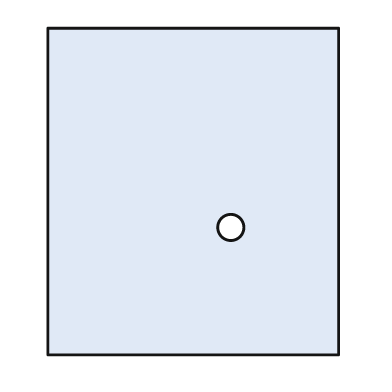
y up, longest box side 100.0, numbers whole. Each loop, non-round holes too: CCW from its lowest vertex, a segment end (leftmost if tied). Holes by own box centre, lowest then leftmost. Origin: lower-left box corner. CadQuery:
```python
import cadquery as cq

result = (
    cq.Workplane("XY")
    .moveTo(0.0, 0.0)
    .lineTo(89.0, 0.0)
    .lineTo(89.0, 100.0)
    .lineTo(0.0, 100.0)
    .close()
    .moveTo(56.0, 39.0)
    .circle(4.0)
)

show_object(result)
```